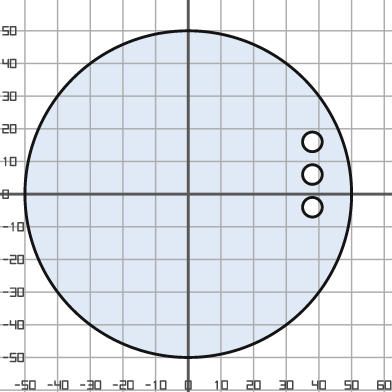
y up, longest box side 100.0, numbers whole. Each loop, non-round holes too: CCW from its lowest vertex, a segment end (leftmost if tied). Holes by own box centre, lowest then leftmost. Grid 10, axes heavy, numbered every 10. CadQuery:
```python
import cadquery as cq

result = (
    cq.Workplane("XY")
    .moveTo(0.0, 0.0)
    .circle(50.0)
    .moveTo(38.0, -4.0)
    .circle(3.0)
    .moveTo(38.0, 6.0)
    .circle(3.0)
    .moveTo(38.0, 16.0)
    .circle(3.0)
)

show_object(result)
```